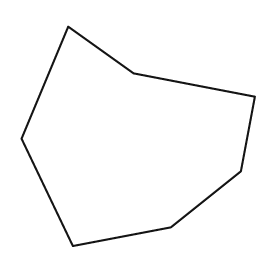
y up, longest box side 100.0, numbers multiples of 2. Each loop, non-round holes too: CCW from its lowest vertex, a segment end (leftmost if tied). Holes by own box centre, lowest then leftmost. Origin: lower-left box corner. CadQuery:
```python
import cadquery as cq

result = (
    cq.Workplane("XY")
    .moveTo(22.0, 0.0)
    .lineTo(64.0, 8.0)
    .lineTo(94.0, 32.0)
    .lineTo(100.0, 64.0)
    .lineTo(48.0, 74.0)
    .lineTo(20.0, 94.0)
    .lineTo(0.0, 46.0)
    .close()
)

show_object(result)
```